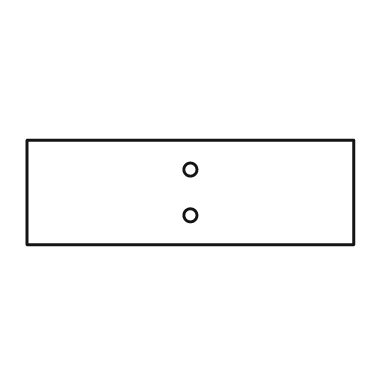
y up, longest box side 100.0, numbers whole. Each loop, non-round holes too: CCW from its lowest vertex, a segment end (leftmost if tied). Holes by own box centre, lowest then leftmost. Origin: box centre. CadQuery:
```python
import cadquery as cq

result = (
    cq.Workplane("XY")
    .moveTo(-50.0, -16.0)
    .lineTo(50.0, -16.0)
    .lineTo(50.0, 16.0)
    .lineTo(-50.0, 16.0)
    .close()
    .moveTo(0.0, -7.0)
    .circle(2.0)
    .moveTo(0.0, 7.0)
    .circle(2.0)
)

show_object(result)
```